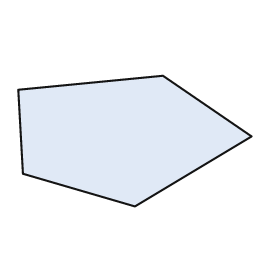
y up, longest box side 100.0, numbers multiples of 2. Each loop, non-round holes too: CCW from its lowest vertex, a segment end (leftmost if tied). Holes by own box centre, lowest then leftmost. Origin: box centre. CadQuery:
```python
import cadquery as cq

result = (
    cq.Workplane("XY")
    .moveTo(0.0, -28.0)
    .lineTo(50.0, 2.0)
    .lineTo(12.0, 28.0)
    .lineTo(-50.0, 22.0)
    .lineTo(-48.0, -14.0)
    .close()
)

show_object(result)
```